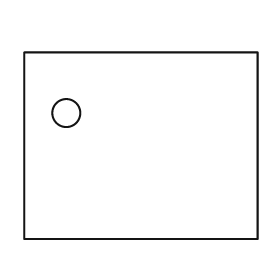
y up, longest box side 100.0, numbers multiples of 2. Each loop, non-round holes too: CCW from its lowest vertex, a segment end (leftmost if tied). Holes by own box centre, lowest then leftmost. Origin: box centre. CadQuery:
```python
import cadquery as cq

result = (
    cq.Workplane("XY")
    .moveTo(-50.0, -40.0)
    .lineTo(50.0, -40.0)
    .lineTo(50.0, 40.0)
    .lineTo(-50.0, 40.0)
    .close()
    .moveTo(-32.0, 14.0)
    .circle(6.0)
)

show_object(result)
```